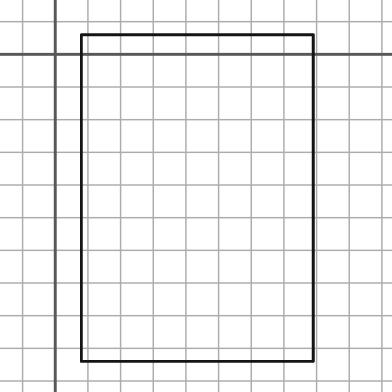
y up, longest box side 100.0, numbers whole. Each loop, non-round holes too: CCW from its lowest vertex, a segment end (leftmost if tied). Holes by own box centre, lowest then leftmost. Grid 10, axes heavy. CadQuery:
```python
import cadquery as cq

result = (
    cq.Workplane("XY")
    .moveTo(8.0, -94.0)
    .lineTo(79.0, -94.0)
    .lineTo(79.0, 6.0)
    .lineTo(8.0, 6.0)
    .close()
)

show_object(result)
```